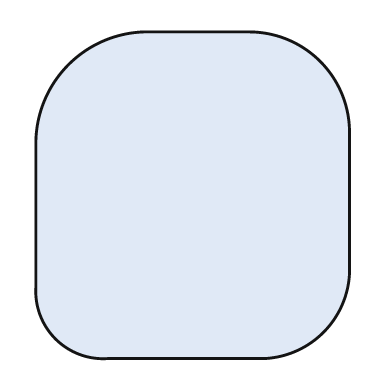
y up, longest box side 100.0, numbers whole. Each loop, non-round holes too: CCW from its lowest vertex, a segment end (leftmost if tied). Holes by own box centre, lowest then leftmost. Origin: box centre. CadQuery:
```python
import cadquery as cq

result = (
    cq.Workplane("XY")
    .moveTo(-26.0, -50.0)
    .lineTo(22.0, -50.0)
    .threePointArc((40.0, -42.0), (48.0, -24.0))
    .lineTo(48.0, 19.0)
    .threePointArc((39.0, 41.0), (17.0, 50.0))
    .lineTo(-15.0, 50.0)
    .threePointArc((-38.0, 40.0), (-48.0, 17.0))
    .lineTo(-48.0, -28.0)
    .threePointArc((-42.0, -44.0), (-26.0, -50.0))
    .close()
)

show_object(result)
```